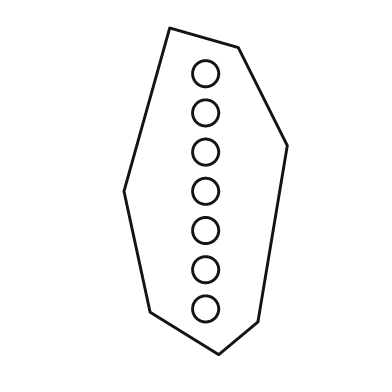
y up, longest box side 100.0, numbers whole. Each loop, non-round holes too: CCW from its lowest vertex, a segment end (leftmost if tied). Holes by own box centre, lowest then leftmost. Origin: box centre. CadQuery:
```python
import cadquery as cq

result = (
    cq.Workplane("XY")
    .moveTo(4.0, -50.0)
    .lineTo(16.0, -40.0)
    .lineTo(25.0, 14.0)
    .lineTo(10.0, 44.0)
    .lineTo(-11.0, 50.0)
    .lineTo(-25.0, 0.0)
    .lineTo(-17.0, -37.0)
    .close()
    .moveTo(0.0, -36.0)
    .circle(4.0)
    .moveTo(0.0, -24.0)
    .circle(4.0)
    .moveTo(0.0, -12.0)
    .circle(4.0)
    .moveTo(0.0, 0.0)
    .circle(4.0)
    .moveTo(0.0, 12.0)
    .circle(4.0)
    .moveTo(0.0, 24.0)
    .circle(4.0)
    .moveTo(0.0, 36.0)
    .circle(4.0)
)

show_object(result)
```